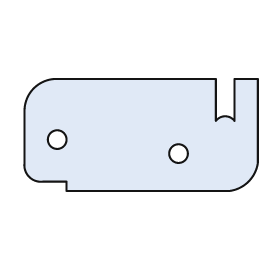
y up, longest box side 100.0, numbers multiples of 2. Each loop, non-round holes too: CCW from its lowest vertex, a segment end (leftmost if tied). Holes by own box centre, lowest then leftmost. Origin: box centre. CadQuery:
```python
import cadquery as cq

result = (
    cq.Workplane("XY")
    .moveTo(-32.0, -24.0)
    .lineTo(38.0, -24.0)
    .threePointArc((46.0, -20.0), (50.0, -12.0))
    .lineTo(50.0, 24.0)
    .lineTo(40.0, 24.0)
    .lineTo(40.0, 6.0)
    .threePointArc((36.0, 8.0), (32.0, 6.0))
    .lineTo(32.0, 24.0)
    .lineTo(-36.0, 24.0)
    .threePointArc((-46.0, 20.0), (-50.0, 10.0))
    .lineTo(-50.0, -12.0)
    .threePointArc((-48.0, -18.0), (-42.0, -20.0))
    .lineTo(-32.0, -20.0)
    .close()
    .moveTo(16.0, -8.0)
    .circle(4.0)
    .moveTo(-36.0, -2.0)
    .circle(4.0)
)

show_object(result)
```